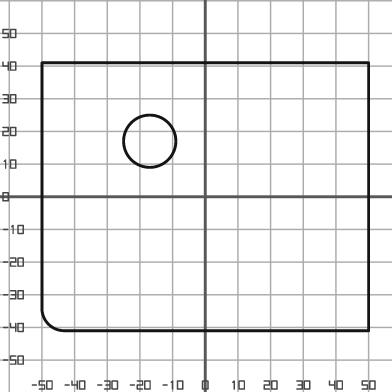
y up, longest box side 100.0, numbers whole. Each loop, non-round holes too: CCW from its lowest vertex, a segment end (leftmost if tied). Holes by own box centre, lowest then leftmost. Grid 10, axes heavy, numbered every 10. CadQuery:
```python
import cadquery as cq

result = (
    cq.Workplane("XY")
    .moveTo(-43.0, -41.0)
    .lineTo(50.0, -41.0)
    .lineTo(50.0, 41.0)
    .lineTo(-50.0, 41.0)
    .lineTo(-50.0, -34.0)
    .threePointArc((-48.0, -39.0), (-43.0, -41.0))
    .close()
    .moveTo(-17.0, 17.0)
    .circle(8.0)
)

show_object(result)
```